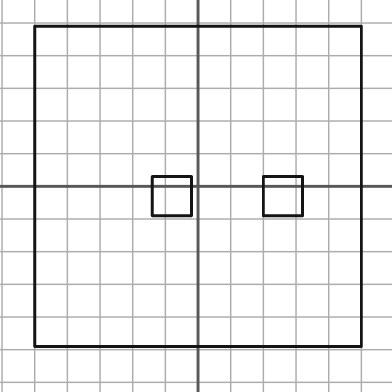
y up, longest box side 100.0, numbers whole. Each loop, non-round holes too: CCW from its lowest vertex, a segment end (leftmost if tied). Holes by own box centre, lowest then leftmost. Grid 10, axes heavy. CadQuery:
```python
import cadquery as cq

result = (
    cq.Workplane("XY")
    .moveTo(-50.0, -49.0)
    .lineTo(50.0, -49.0)
    .lineTo(50.0, 49.0)
    .lineTo(-50.0, 49.0)
    .close()
    .moveTo(-14.0, -9.0)
    .lineTo(-2.0, -9.0)
    .lineTo(-2.0, 3.0)
    .lineTo(-14.0, 3.0)
    .close()
    .moveTo(20.0, -9.0)
    .lineTo(32.0, -9.0)
    .lineTo(32.0, 3.0)
    .lineTo(20.0, 3.0)
    .close()
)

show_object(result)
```